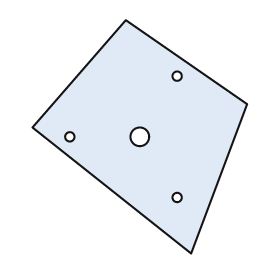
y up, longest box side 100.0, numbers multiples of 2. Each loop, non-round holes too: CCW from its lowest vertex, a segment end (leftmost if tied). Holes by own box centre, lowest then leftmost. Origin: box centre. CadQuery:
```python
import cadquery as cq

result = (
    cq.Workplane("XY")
    .moveTo(22.0, -50.0)
    .lineTo(46.0, 14.0)
    .lineTo(-6.0, 50.0)
    .lineTo(-46.0, 4.0)
    .close()
    .moveTo(16.0, -26.0)
    .circle(2.0)
    .moveTo(-30.0, 0.0)
    .circle(2.0)
    .moveTo(0.0, 0.0)
    .circle(4.0)
    .moveTo(16.0, 26.0)
    .circle(2.0)
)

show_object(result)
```